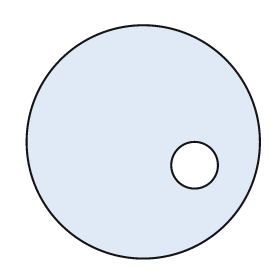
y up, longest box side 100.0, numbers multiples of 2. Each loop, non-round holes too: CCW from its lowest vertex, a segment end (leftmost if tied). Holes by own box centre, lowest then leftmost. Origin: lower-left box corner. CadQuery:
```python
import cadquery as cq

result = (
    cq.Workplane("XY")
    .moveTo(50.0, 50.0)
    .circle(50.0)
    .moveTo(72.0, 40.0)
    .circle(10.0)
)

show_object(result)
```